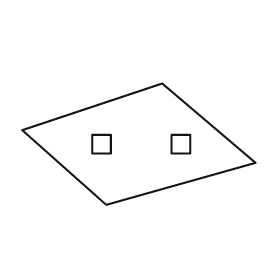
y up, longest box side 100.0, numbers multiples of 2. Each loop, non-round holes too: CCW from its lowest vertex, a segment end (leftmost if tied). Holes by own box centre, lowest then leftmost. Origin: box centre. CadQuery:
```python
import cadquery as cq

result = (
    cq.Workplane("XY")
    .moveTo(-14.0, -26.0)
    .lineTo(50.0, -8.0)
    .lineTo(10.0, 26.0)
    .lineTo(-50.0, 6.0)
    .close()
    .moveTo(-20.0, -4.0)
    .lineTo(-12.0, -4.0)
    .lineTo(-12.0, 4.0)
    .lineTo(-20.0, 4.0)
    .close()
    .moveTo(14.0, -4.0)
    .lineTo(22.0, -4.0)
    .lineTo(22.0, 4.0)
    .lineTo(14.0, 4.0)
    .close()
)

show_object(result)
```